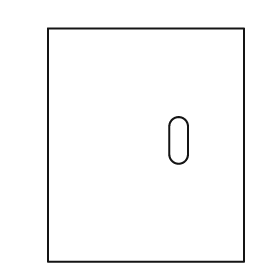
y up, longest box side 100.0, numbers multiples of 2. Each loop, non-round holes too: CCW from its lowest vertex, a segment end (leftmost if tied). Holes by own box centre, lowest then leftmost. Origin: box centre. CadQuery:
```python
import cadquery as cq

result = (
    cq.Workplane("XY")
    .moveTo(-42.0, -50.0)
    .lineTo(42.0, -50.0)
    .lineTo(42.0, 50.0)
    .lineTo(-42.0, 50.0)
    .close()
    .moveTo(10.0, -4.0)
    .threePointArc((14.0, -8.0), (18.0, -4.0))
    .lineTo(18.0, 8.0)
    .threePointArc((14.0, 12.0), (10.0, 8.0))
    .close()
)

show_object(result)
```